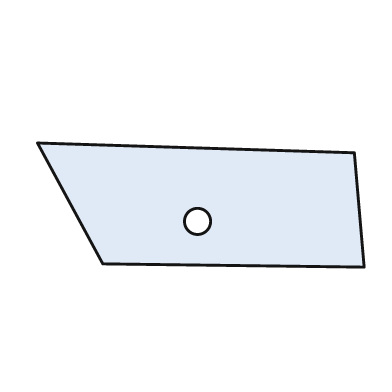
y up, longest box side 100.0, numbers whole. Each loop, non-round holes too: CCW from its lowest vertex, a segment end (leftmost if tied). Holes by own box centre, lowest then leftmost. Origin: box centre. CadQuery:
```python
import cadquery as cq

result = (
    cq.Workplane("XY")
    .moveTo(50.0, -19.0)
    .lineTo(47.0, 16.0)
    .lineTo(-50.0, 19.0)
    .lineTo(-30.0, -18.0)
    .close()
    .moveTo(-1.0, -5.0)
    .circle(4.0)
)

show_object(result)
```